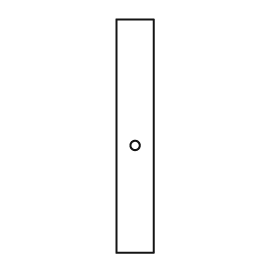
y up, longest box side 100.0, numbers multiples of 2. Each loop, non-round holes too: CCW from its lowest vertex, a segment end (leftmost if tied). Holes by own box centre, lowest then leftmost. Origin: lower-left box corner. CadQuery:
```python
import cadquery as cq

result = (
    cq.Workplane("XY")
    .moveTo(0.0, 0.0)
    .lineTo(16.0, 0.0)
    .lineTo(16.0, 100.0)
    .lineTo(0.0, 100.0)
    .close()
    .moveTo(8.0, 46.0)
    .circle(2.0)
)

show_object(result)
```